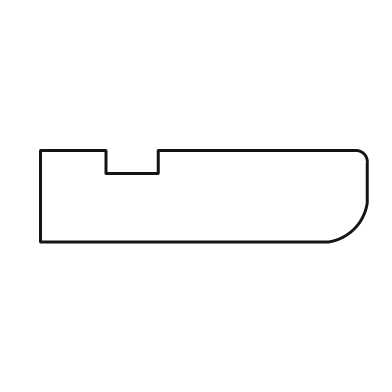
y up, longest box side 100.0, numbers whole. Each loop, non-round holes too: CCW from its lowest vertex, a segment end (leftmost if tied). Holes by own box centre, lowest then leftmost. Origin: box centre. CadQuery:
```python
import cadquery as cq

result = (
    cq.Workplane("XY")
    .moveTo(-50.0, -14.0)
    .lineTo(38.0, -14.0)
    .threePointArc((46.0, -10.0), (50.0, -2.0))
    .lineTo(50.0, 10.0)
    .threePointArc((49.0, 13.0), (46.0, 14.0))
    .lineTo(-14.0, 14.0)
    .lineTo(-14.0, 7.0)
    .lineTo(-30.0, 7.0)
    .lineTo(-30.0, 14.0)
    .lineTo(-50.0, 14.0)
    .close()
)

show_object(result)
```